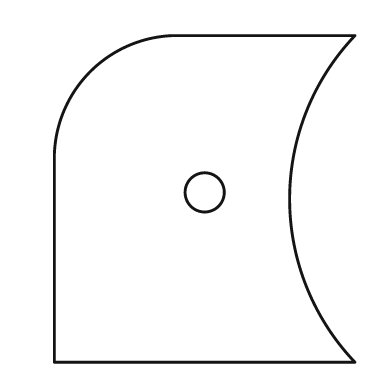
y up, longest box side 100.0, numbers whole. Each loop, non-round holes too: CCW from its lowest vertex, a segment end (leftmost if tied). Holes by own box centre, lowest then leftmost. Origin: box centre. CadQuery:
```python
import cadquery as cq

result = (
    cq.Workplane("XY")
    .moveTo(-46.0, -50.0)
    .lineTo(46.0, -50.0)
    .threePointArc((26.0, 0.0), (46.0, 50.0))
    .lineTo(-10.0, 50.0)
    .threePointArc((-35.0, 39.0), (-46.0, 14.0))
    .close()
    .moveTo(0.0, 2.0)
    .circle(6.0)
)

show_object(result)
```